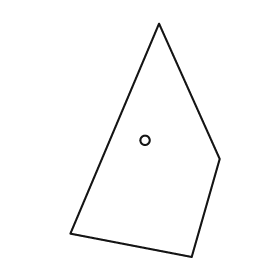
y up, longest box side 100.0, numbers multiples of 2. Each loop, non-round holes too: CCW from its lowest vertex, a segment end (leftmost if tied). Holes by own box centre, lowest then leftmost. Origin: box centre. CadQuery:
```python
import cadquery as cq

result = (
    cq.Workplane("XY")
    .moveTo(20.0, -50.0)
    .lineTo(32.0, -8.0)
    .lineTo(6.0, 50.0)
    .lineTo(-32.0, -40.0)
    .close()
    .moveTo(0.0, 0.0)
    .circle(2.0)
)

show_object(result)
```